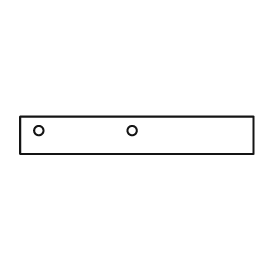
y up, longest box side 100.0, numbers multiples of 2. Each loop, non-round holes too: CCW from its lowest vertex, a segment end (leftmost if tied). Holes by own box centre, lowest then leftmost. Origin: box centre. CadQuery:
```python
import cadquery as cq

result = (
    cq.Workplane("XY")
    .moveTo(-50.0, -8.0)
    .lineTo(50.0, -8.0)
    .lineTo(50.0, 8.0)
    .lineTo(-50.0, 8.0)
    .close()
    .moveTo(-42.0, 2.0)
    .circle(2.0)
    .moveTo(-2.0, 2.0)
    .circle(2.0)
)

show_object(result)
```